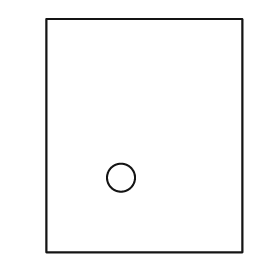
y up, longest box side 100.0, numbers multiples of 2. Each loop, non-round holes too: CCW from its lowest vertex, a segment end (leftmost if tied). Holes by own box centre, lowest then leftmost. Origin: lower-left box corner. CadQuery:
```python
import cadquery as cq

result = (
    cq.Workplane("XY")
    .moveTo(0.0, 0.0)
    .lineTo(84.0, 0.0)
    .lineTo(84.0, 100.0)
    .lineTo(0.0, 100.0)
    .close()
    .moveTo(32.0, 32.0)
    .circle(6.0)
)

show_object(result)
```